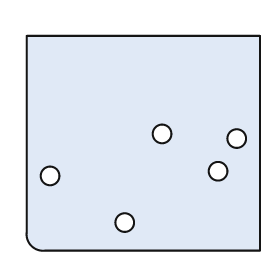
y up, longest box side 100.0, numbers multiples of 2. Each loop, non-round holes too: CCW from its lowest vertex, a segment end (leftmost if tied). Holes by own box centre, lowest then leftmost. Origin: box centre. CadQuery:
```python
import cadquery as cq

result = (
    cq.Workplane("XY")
    .moveTo(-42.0, -46.0)
    .lineTo(50.0, -46.0)
    .lineTo(50.0, 46.0)
    .lineTo(-50.0, 46.0)
    .lineTo(-50.0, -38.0)
    .threePointArc((-48.0, -44.0), (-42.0, -46.0))
    .close()
    .moveTo(-8.0, -34.0)
    .circle(4.0)
    .moveTo(-40.0, -14.0)
    .circle(4.0)
    .moveTo(32.0, -12.0)
    .circle(4.0)
    .moveTo(40.0, 2.0)
    .circle(4.0)
    .moveTo(8.0, 4.0)
    .circle(4.0)
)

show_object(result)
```